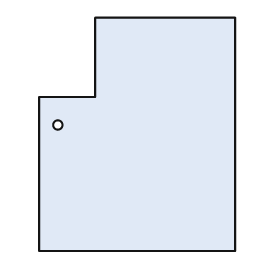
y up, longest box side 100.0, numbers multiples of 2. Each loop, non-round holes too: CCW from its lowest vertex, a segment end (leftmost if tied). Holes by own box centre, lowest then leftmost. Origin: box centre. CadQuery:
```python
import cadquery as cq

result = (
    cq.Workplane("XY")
    .moveTo(-42.0, -50.0)
    .lineTo(42.0, -50.0)
    .lineTo(42.0, 50.0)
    .lineTo(-18.0, 50.0)
    .lineTo(-18.0, 16.0)
    .lineTo(-42.0, 16.0)
    .close()
    .moveTo(-34.0, 4.0)
    .circle(2.0)
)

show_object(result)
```